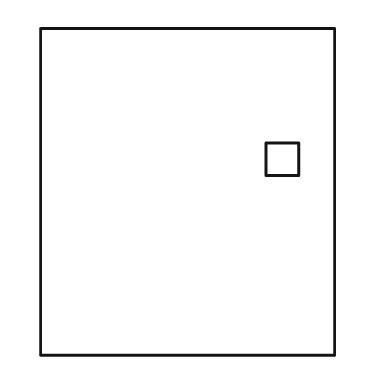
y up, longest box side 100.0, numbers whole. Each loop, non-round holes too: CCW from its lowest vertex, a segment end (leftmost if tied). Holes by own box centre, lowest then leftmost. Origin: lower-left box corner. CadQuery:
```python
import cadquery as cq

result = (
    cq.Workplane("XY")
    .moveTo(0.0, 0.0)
    .lineTo(90.0, 0.0)
    .lineTo(90.0, 100.0)
    .lineTo(0.0, 100.0)
    .close()
    .moveTo(69.0, 55.0)
    .lineTo(79.0, 55.0)
    .lineTo(79.0, 65.0)
    .lineTo(69.0, 65.0)
    .close()
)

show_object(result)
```